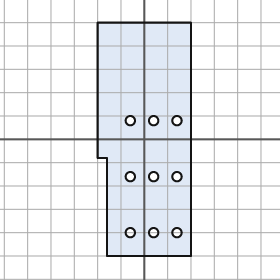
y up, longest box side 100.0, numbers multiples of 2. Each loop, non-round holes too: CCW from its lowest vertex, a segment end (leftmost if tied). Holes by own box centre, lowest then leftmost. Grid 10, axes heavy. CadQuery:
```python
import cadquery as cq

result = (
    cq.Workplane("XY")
    .moveTo(-16.0, -50.0)
    .lineTo(20.0, -50.0)
    .lineTo(20.0, 50.0)
    .lineTo(-20.0, 50.0)
    .lineTo(-20.0, -8.0)
    .lineTo(-16.0, -8.0)
    .close()
    .moveTo(-6.0, -40.0)
    .circle(2.0)
    .moveTo(4.0, -40.0)
    .circle(2.0)
    .moveTo(14.0, -40.0)
    .circle(2.0)
    .moveTo(-6.0, -16.0)
    .circle(2.0)
    .moveTo(4.0, -16.0)
    .circle(2.0)
    .moveTo(14.0, -16.0)
    .circle(2.0)
    .moveTo(-6.0, 8.0)
    .circle(2.0)
    .moveTo(4.0, 8.0)
    .circle(2.0)
    .moveTo(14.0, 8.0)
    .circle(2.0)
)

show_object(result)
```